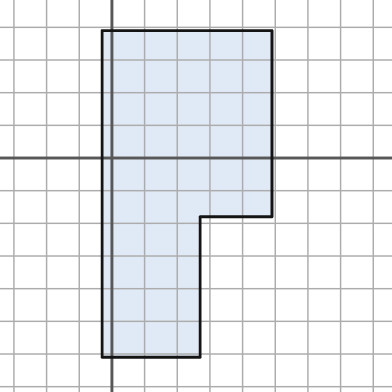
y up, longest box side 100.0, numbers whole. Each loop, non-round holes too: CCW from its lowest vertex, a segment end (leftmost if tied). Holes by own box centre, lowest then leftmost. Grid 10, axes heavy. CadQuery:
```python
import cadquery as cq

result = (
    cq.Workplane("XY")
    .moveTo(-3.0, -61.0)
    .lineTo(27.0, -61.0)
    .lineTo(27.0, -18.0)
    .lineTo(49.0, -18.0)
    .lineTo(49.0, 39.0)
    .lineTo(-3.0, 39.0)
    .close()
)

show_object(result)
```